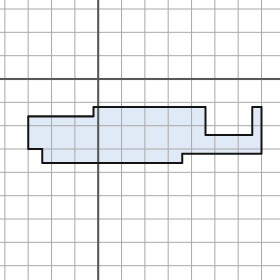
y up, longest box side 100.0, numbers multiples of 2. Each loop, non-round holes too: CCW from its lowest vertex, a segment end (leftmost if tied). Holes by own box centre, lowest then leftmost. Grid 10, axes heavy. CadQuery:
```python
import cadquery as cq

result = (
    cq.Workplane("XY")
    .moveTo(-24.0, -36.0)
    .lineTo(36.0, -36.0)
    .lineTo(36.0, -32.0)
    .lineTo(70.0, -32.0)
    .lineTo(70.0, -12.0)
    .lineTo(66.0, -12.0)
    .lineTo(66.0, -24.0)
    .lineTo(46.0, -24.0)
    .lineTo(46.0, -12.0)
    .lineTo(-2.0, -12.0)
    .lineTo(-2.0, -16.0)
    .lineTo(-30.0, -16.0)
    .lineTo(-30.0, -30.0)
    .lineTo(-24.0, -30.0)
    .close()
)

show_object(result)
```